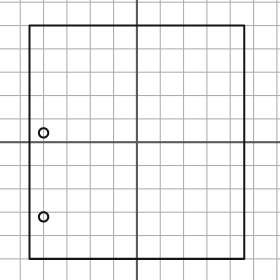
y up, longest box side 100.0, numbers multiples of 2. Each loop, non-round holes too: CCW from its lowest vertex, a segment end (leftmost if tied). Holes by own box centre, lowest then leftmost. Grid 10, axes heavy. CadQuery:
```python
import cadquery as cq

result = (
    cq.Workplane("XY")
    .moveTo(-46.0, -50.0)
    .lineTo(46.0, -50.0)
    .lineTo(46.0, 50.0)
    .lineTo(-46.0, 50.0)
    .close()
    .moveTo(-40.0, -32.0)
    .circle(2.0)
    .moveTo(-40.0, 4.0)
    .circle(2.0)
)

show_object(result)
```